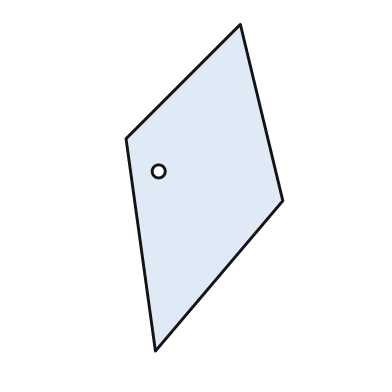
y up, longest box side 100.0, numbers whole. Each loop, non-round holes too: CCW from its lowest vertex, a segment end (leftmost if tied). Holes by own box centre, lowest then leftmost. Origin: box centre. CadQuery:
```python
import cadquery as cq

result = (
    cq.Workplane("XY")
    .moveTo(-15.0, -50.0)
    .lineTo(24.0, -4.0)
    .lineTo(11.0, 50.0)
    .lineTo(-24.0, 15.0)
    .close()
    .moveTo(-14.0, 5.0)
    .circle(2.0)
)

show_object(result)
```